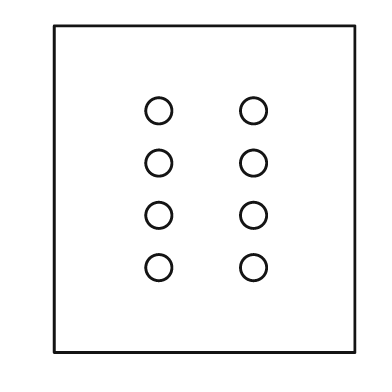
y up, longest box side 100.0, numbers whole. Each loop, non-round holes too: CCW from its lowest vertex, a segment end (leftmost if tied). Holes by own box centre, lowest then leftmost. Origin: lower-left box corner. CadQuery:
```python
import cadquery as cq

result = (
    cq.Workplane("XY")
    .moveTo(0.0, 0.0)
    .lineTo(92.0, 0.0)
    .lineTo(92.0, 100.0)
    .lineTo(0.0, 100.0)
    .close()
    .moveTo(32.0, 26.0)
    .circle(4.0)
    .moveTo(61.0, 26.0)
    .circle(4.0)
    .moveTo(32.0, 42.0)
    .circle(4.0)
    .moveTo(61.0, 42.0)
    .circle(4.0)
    .moveTo(32.0, 58.0)
    .circle(4.0)
    .moveTo(61.0, 58.0)
    .circle(4.0)
    .moveTo(32.0, 74.0)
    .circle(4.0)
    .moveTo(61.0, 74.0)
    .circle(4.0)
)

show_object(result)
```